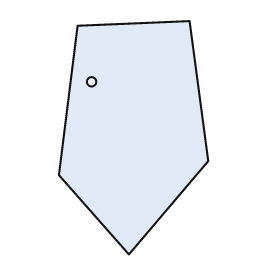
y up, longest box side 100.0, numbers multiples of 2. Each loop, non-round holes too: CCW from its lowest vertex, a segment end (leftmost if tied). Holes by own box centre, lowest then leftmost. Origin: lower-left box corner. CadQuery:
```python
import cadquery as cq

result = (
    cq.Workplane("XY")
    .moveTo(30.0, 0.0)
    .lineTo(64.0, 40.0)
    .lineTo(56.0, 100.0)
    .lineTo(8.0, 98.0)
    .lineTo(0.0, 34.0)
    .close()
    .moveTo(14.0, 74.0)
    .circle(2.0)
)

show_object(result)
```